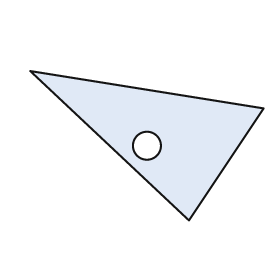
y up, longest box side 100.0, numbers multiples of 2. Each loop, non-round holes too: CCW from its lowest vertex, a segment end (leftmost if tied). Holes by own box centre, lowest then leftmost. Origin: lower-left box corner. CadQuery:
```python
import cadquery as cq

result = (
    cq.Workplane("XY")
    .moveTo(68.0, 0.0)
    .lineTo(100.0, 48.0)
    .lineTo(0.0, 64.0)
    .close()
    .moveTo(50.0, 32.0)
    .circle(6.0)
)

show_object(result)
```